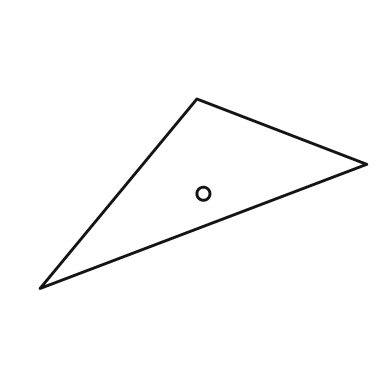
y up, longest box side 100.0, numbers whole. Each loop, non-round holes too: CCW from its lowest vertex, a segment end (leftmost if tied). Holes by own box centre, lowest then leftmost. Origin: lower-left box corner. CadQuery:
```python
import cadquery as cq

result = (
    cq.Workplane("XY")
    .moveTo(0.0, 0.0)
    .lineTo(100.0, 38.0)
    .lineTo(48.0, 58.0)
    .close()
    .moveTo(50.0, 29.0)
    .circle(2.0)
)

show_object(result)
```